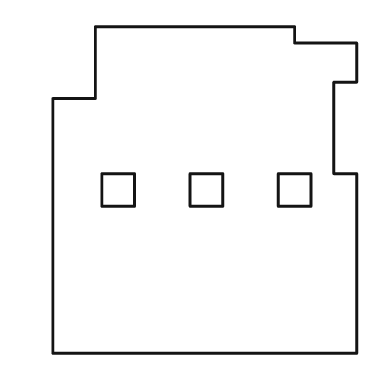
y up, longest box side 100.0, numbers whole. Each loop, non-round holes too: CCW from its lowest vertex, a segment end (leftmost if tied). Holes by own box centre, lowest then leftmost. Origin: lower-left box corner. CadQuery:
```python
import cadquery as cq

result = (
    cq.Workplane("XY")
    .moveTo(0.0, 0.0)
    .lineTo(93.0, 0.0)
    .lineTo(93.0, 55.0)
    .lineTo(86.0, 55.0)
    .lineTo(86.0, 83.0)
    .lineTo(93.0, 83.0)
    .lineTo(93.0, 95.0)
    .lineTo(74.0, 95.0)
    .lineTo(74.0, 100.0)
    .lineTo(13.0, 100.0)
    .lineTo(13.0, 78.0)
    .lineTo(0.0, 78.0)
    .close()
    .moveTo(15.0, 45.0)
    .lineTo(25.0, 45.0)
    .lineTo(25.0, 55.0)
    .lineTo(15.0, 55.0)
    .close()
    .moveTo(42.0, 45.0)
    .lineTo(52.0, 45.0)
    .lineTo(52.0, 55.0)
    .lineTo(42.0, 55.0)
    .close()
    .moveTo(69.0, 45.0)
    .lineTo(79.0, 45.0)
    .lineTo(79.0, 55.0)
    .lineTo(69.0, 55.0)
    .close()
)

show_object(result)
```